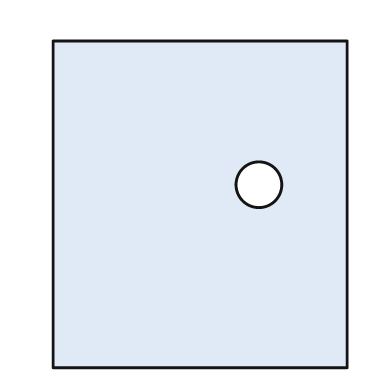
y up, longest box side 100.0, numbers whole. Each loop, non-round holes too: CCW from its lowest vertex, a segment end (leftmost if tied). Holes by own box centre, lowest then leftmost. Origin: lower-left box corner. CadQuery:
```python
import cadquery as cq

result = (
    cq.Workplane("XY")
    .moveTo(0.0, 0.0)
    .lineTo(90.0, 0.0)
    .lineTo(90.0, 100.0)
    .lineTo(0.0, 100.0)
    .close()
    .moveTo(63.0, 56.0)
    .circle(7.0)
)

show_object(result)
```